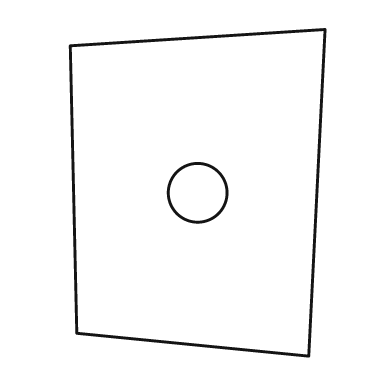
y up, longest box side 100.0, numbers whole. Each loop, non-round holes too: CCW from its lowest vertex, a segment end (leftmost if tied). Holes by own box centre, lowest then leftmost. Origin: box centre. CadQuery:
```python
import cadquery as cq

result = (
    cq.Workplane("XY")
    .moveTo(34.0, -50.0)
    .lineTo(39.0, 50.0)
    .lineTo(-39.0, 45.0)
    .lineTo(-37.0, -43.0)
    .close()
    .moveTo(0.0, 0.0)
    .circle(9.0)
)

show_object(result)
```